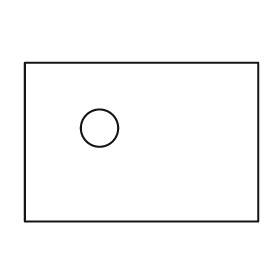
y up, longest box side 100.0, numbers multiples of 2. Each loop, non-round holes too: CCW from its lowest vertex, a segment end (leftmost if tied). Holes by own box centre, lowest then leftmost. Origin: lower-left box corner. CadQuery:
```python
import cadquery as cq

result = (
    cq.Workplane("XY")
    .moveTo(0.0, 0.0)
    .lineTo(100.0, 0.0)
    .lineTo(100.0, 68.0)
    .lineTo(0.0, 68.0)
    .close()
    .moveTo(32.0, 40.0)
    .circle(8.0)
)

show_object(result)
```